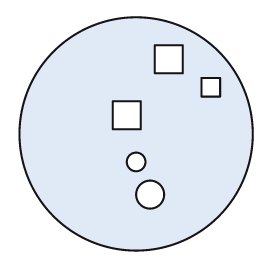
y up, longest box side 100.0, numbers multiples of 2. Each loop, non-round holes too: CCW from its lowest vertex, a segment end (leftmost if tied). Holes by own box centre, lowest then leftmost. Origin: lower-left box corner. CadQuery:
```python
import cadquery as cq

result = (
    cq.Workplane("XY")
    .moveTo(50.0, 50.0)
    .circle(50.0)
    .moveTo(56.0, 24.0)
    .circle(6.0)
    .moveTo(50.0, 38.0)
    .circle(4.0)
    .moveTo(40.0, 52.0)
    .lineTo(52.0, 52.0)
    .lineTo(52.0, 64.0)
    .lineTo(40.0, 64.0)
    .close()
    .moveTo(78.0, 66.0)
    .lineTo(86.0, 66.0)
    .lineTo(86.0, 74.0)
    .lineTo(78.0, 74.0)
    .close()
    .moveTo(58.0, 76.0)
    .lineTo(70.0, 76.0)
    .lineTo(70.0, 88.0)
    .lineTo(58.0, 88.0)
    .close()
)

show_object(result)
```